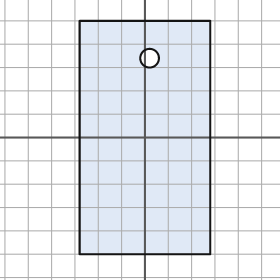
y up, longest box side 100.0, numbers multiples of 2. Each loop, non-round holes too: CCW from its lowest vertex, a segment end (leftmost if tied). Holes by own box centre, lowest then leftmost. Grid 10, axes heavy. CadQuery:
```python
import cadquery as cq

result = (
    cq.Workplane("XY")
    .moveTo(-28.0, -50.0)
    .lineTo(28.0, -50.0)
    .lineTo(28.0, 50.0)
    .lineTo(-28.0, 50.0)
    .close()
    .moveTo(2.0, 34.0)
    .circle(4.0)
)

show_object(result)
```